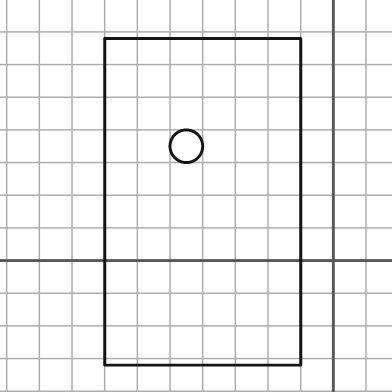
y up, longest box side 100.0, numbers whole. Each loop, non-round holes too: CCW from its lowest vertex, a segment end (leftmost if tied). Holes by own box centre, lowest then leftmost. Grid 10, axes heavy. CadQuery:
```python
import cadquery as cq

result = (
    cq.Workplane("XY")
    .moveTo(-70.0, -32.0)
    .lineTo(-10.0, -32.0)
    .lineTo(-10.0, 68.0)
    .lineTo(-70.0, 68.0)
    .close()
    .moveTo(-45.0, 35.0)
    .circle(5.0)
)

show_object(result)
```